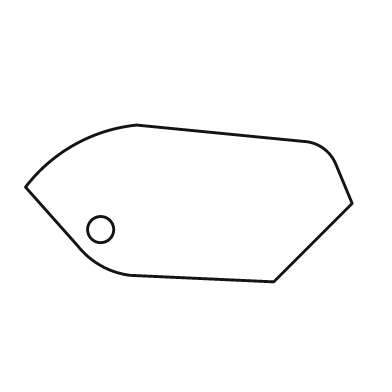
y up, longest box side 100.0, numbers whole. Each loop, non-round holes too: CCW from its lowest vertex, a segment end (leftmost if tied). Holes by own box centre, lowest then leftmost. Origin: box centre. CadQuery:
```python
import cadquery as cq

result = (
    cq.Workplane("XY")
    .moveTo(26.0, -24.0)
    .lineTo(50.0, 0.0)
    .lineTo(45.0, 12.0)
    .threePointArc((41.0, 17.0), (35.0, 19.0))
    .lineTo(-16.0, 24.0)
    .threePointArc((-35.0, 18.0), (-50.0, 5.0))
    .lineTo(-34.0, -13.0)
    .threePointArc((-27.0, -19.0), (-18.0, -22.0))
    .close()
    .moveTo(-27.0, -8.0)
    .circle(4.0)
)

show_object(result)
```